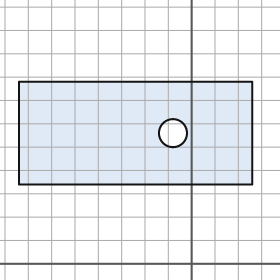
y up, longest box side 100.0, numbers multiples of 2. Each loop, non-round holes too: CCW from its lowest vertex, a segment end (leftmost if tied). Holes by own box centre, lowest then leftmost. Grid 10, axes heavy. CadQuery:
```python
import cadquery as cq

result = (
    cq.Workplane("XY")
    .moveTo(-74.0, 34.0)
    .lineTo(26.0, 34.0)
    .lineTo(26.0, 78.0)
    .lineTo(-74.0, 78.0)
    .close()
    .moveTo(-8.0, 56.0)
    .circle(6.0)
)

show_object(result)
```